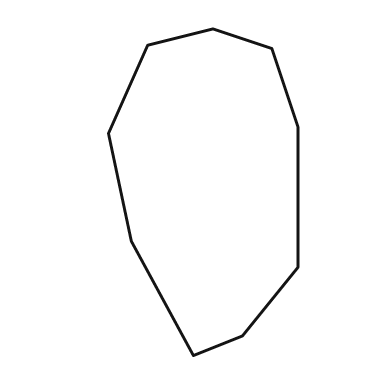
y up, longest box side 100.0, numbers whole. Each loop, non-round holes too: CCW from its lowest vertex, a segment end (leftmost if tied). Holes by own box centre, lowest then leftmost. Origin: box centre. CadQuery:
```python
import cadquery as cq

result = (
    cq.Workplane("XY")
    .moveTo(-3.0, -50.0)
    .lineTo(12.0, -44.0)
    .lineTo(29.0, -23.0)
    .lineTo(29.0, 20.0)
    .lineTo(21.0, 44.0)
    .lineTo(3.0, 50.0)
    .lineTo(-17.0, 45.0)
    .lineTo(-29.0, 18.0)
    .lineTo(-22.0, -15.0)
    .close()
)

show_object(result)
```